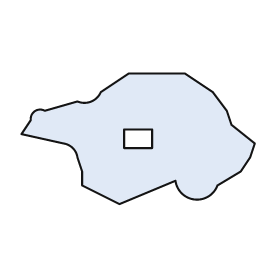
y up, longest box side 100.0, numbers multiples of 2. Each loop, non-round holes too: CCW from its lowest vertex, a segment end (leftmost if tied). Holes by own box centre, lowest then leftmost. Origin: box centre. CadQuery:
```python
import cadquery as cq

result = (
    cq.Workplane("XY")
    .moveTo(-8.0, -28.0)
    .lineTo(16.0, -18.0)
    .threePointArc((24.0, -26.0), (34.0, -20.0))
    .lineTo(44.0, -14.0)
    .lineTo(48.0, -8.0)
    .lineTo(50.0, -2.0)
    .lineTo(40.0, 6.0)
    .lineTo(38.0, 12.0)
    .lineTo(32.0, 20.0)
    .lineTo(20.0, 28.0)
    .lineTo(-4.0, 28.0)
    .lineTo(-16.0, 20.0)
    .threePointArc((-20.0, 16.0), (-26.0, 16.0))
    .lineTo(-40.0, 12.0)
    .threePointArc((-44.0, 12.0), (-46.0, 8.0))
    .lineTo(-50.0, 2.0)
    .lineTo(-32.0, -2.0)
    .threePointArc((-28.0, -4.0), (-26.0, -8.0))
    .lineTo(-24.0, -14.0)
    .lineTo(-24.0, -20.0)
    .close()
    .moveTo(-6.0, -4.0)
    .lineTo(6.0, -4.0)
    .lineTo(6.0, 4.0)
    .lineTo(-6.0, 4.0)
    .close()
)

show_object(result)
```